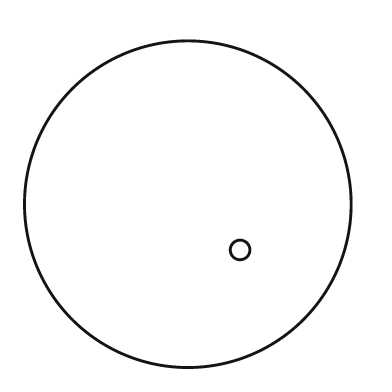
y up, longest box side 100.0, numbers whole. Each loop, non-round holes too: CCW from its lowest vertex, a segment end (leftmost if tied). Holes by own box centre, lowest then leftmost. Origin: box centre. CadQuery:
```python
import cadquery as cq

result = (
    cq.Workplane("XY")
    .moveTo(0.0, 0.0)
    .circle(50.0)
    .moveTo(16.0, -14.0)
    .circle(3.0)
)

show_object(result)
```